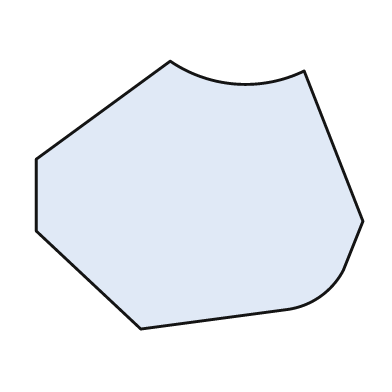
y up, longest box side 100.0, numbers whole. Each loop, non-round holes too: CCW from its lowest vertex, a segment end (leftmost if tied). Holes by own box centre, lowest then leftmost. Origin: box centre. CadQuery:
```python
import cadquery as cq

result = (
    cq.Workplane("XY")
    .moveTo(-18.0, -41.0)
    .lineTo(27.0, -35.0)
    .threePointArc((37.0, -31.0), (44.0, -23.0))
    .lineTo(50.0, -8.0)
    .lineTo(32.0, 38.0)
    .threePointArc((11.0, 34.0), (-9.0, 41.0))
    .lineTo(-50.0, 11.0)
    .lineTo(-50.0, -11.0)
    .close()
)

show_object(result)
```